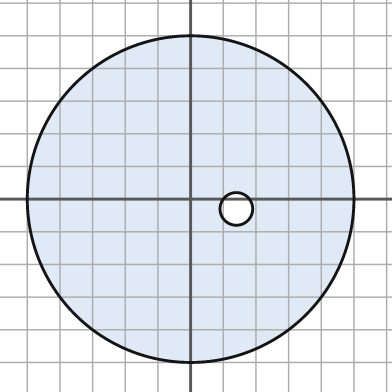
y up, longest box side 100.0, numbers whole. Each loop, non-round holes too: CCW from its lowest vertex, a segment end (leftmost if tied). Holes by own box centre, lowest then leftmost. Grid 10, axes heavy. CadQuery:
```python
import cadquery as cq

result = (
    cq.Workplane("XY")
    .moveTo(0.0, 0.0)
    .circle(50.0)
    .moveTo(14.0, -3.0)
    .circle(5.0)
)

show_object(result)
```